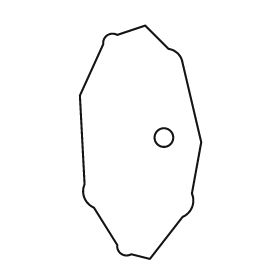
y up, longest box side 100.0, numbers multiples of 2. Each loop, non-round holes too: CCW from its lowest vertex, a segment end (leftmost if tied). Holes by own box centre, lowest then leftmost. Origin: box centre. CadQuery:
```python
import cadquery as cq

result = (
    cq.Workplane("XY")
    .moveTo(4.0, -50.0)
    .lineTo(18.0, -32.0)
    .threePointArc((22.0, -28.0), (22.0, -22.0))
    .lineTo(26.0, 0.0)
    .lineTo(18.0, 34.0)
    .threePointArc((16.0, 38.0), (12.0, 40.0))
    .lineTo(2.0, 50.0)
    .lineTo(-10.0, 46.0)
    .threePointArc((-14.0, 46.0), (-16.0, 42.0))
    .lineTo(-26.0, 20.0)
    .lineTo(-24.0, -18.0)
    .threePointArc((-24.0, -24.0), (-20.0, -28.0))
    .lineTo(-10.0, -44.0)
    .threePointArc((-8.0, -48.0), (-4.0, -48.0))
    .close()
    .moveTo(10.0, 2.0)
    .circle(4.0)
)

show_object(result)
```